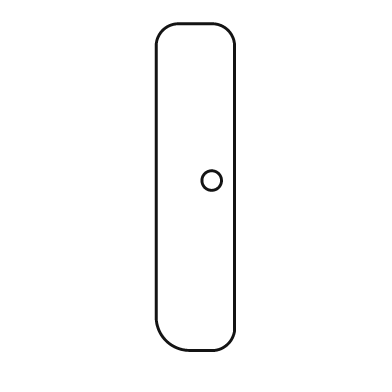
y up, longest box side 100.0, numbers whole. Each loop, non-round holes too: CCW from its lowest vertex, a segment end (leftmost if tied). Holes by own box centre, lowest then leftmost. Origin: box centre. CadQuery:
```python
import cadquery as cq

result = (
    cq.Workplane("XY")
    .moveTo(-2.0, -50.0)
    .lineTo(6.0, -50.0)
    .threePointArc((10.0, -48.0), (12.0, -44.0))
    .lineTo(12.0, 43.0)
    .threePointArc((10.0, 48.0), (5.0, 50.0))
    .lineTo(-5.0, 50.0)
    .threePointArc((-10.0, 48.0), (-12.0, 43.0))
    .lineTo(-12.0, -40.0)
    .threePointArc((-9.0, -47.0), (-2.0, -50.0))
    .close()
    .moveTo(5.0, 2.0)
    .circle(3.0)
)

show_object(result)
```